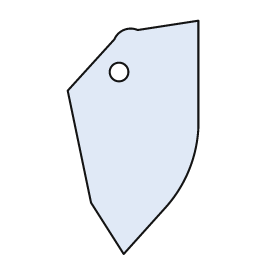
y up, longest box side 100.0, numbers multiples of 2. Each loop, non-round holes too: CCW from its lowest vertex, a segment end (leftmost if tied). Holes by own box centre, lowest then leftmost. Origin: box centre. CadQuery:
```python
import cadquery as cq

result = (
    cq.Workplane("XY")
    .moveTo(-4.0, -50.0)
    .lineTo(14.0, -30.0)
    .threePointArc((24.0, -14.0), (28.0, 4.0))
    .lineTo(28.0, 50.0)
    .lineTo(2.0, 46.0)
    .threePointArc((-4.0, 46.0), (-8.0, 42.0))
    .lineTo(-28.0, 20.0)
    .lineTo(-18.0, -28.0)
    .close()
    .moveTo(-6.0, 28.0)
    .circle(4.0)
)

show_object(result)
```